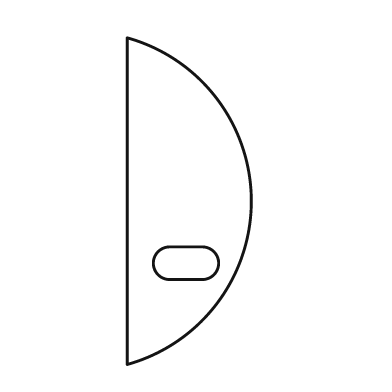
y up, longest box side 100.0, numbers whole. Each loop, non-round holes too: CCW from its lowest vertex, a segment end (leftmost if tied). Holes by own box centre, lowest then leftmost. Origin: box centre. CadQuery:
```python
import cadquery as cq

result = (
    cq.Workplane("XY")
    .moveTo(-19.0, -50.0)
    .threePointArc((19.0, 0.0), (-19.0, 50.0))
    .close()
    .moveTo(-6.0, -24.0)
    .lineTo(4.0, -24.0)
    .threePointArc((9.0, -19.0), (4.0, -14.0))
    .lineTo(-6.0, -14.0)
    .threePointArc((-11.0, -19.0), (-6.0, -24.0))
    .close()
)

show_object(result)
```